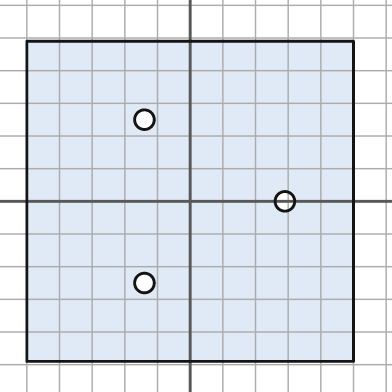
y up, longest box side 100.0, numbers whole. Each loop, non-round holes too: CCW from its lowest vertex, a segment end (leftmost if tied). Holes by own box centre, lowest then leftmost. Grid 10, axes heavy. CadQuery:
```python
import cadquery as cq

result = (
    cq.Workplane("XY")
    .moveTo(-50.0, -49.0)
    .lineTo(50.0, -49.0)
    .lineTo(50.0, 49.0)
    .lineTo(-50.0, 49.0)
    .close()
    .moveTo(-14.0, -25.0)
    .circle(3.0)
    .moveTo(29.0, 0.0)
    .circle(3.0)
    .moveTo(-14.0, 25.0)
    .circle(3.0)
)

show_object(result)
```